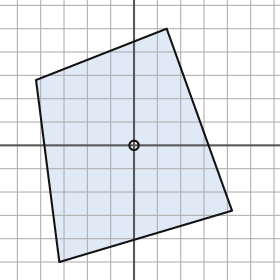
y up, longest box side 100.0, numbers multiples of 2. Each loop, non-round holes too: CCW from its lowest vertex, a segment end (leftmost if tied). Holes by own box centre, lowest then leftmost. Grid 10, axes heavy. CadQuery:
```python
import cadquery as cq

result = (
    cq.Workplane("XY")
    .moveTo(-32.0, -50.0)
    .lineTo(42.0, -28.0)
    .lineTo(14.0, 50.0)
    .lineTo(-42.0, 28.0)
    .close()
    .moveTo(0.0, 0.0)
    .circle(2.0)
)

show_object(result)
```